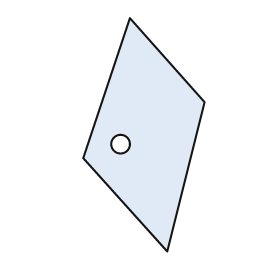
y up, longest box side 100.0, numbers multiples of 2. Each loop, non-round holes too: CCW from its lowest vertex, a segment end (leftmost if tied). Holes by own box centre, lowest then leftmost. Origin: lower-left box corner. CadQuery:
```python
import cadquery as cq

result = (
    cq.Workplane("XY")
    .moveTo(36.0, 0.0)
    .lineTo(52.0, 64.0)
    .lineTo(20.0, 100.0)
    .lineTo(0.0, 40.0)
    .close()
    .moveTo(16.0, 46.0)
    .circle(4.0)
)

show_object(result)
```